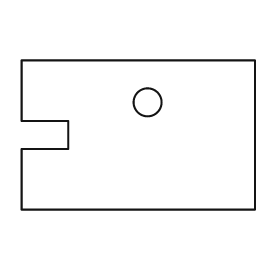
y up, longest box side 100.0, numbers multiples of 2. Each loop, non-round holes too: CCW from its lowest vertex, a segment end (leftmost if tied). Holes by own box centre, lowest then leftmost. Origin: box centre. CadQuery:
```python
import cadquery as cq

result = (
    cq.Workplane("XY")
    .moveTo(-50.0, -32.0)
    .lineTo(50.0, -32.0)
    .lineTo(50.0, 32.0)
    .lineTo(-50.0, 32.0)
    .lineTo(-50.0, 6.0)
    .lineTo(-30.0, 6.0)
    .lineTo(-30.0, -6.0)
    .lineTo(-50.0, -6.0)
    .close()
    .moveTo(4.0, 14.0)
    .circle(6.0)
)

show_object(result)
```